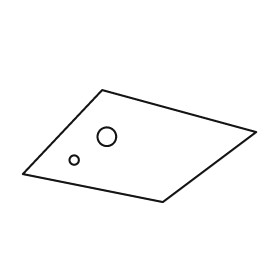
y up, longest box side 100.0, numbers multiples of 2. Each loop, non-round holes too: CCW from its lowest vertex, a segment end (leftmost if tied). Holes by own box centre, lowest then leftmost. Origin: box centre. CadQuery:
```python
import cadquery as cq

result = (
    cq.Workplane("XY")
    .moveTo(10.0, -24.0)
    .lineTo(50.0, 6.0)
    .lineTo(-16.0, 24.0)
    .lineTo(-50.0, -12.0)
    .close()
    .moveTo(-28.0, -6.0)
    .circle(2.0)
    .moveTo(-14.0, 4.0)
    .circle(4.0)
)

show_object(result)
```